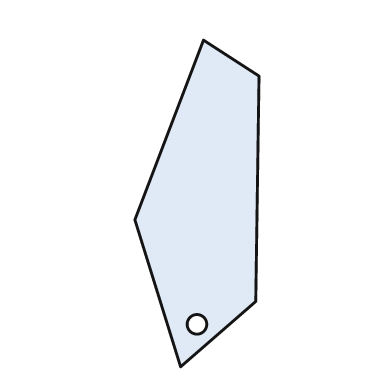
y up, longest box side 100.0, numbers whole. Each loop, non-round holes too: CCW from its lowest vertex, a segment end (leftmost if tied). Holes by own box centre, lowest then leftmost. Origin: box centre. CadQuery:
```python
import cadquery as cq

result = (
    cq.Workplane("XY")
    .moveTo(-5.0, -50.0)
    .lineTo(18.0, -30.0)
    .lineTo(19.0, 39.0)
    .lineTo(2.0, 50.0)
    .lineTo(-19.0, -5.0)
    .close()
    .moveTo(0.0, -37.0)
    .circle(3.0)
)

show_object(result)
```